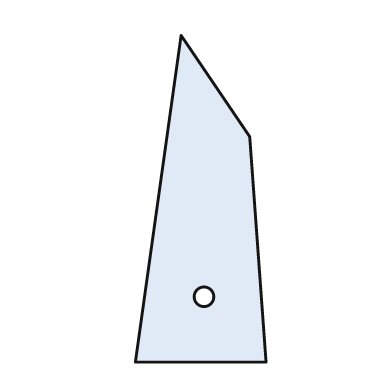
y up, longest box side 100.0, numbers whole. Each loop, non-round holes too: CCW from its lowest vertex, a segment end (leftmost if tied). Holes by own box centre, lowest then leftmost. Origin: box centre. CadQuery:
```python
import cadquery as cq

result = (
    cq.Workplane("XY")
    .moveTo(-20.0, -50.0)
    .lineTo(20.0, -50.0)
    .lineTo(15.0, 19.0)
    .lineTo(-6.0, 50.0)
    .close()
    .moveTo(1.0, -30.0)
    .circle(3.0)
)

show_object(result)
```